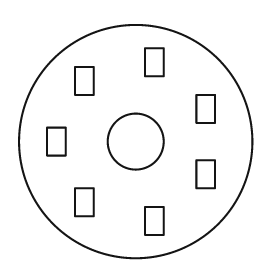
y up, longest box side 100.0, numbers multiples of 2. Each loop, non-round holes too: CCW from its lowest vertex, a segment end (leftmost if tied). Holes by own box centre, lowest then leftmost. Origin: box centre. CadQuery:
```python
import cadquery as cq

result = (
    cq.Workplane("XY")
    .moveTo(0.0, 0.0)
    .circle(50.0)
    .moveTo(4.0, -40.0)
    .lineTo(12.0, -40.0)
    .lineTo(12.0, -28.0)
    .lineTo(4.0, -28.0)
    .close()
    .moveTo(-26.0, -32.0)
    .lineTo(-18.0, -32.0)
    .lineTo(-18.0, -20.0)
    .lineTo(-26.0, -20.0)
    .close()
    .moveTo(26.0, -20.0)
    .lineTo(34.0, -20.0)
    .lineTo(34.0, -8.0)
    .lineTo(26.0, -8.0)
    .close()
    .moveTo(-38.0, -6.0)
    .lineTo(-30.0, -6.0)
    .lineTo(-30.0, 6.0)
    .lineTo(-38.0, 6.0)
    .close()
    .moveTo(0.0, 0.0)
    .circle(12.0)
    .moveTo(26.0, 8.0)
    .lineTo(34.0, 8.0)
    .lineTo(34.0, 20.0)
    .lineTo(26.0, 20.0)
    .close()
    .moveTo(-26.0, 20.0)
    .lineTo(-18.0, 20.0)
    .lineTo(-18.0, 32.0)
    .lineTo(-26.0, 32.0)
    .close()
    .moveTo(4.0, 28.0)
    .lineTo(12.0, 28.0)
    .lineTo(12.0, 40.0)
    .lineTo(4.0, 40.0)
    .close()
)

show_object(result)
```